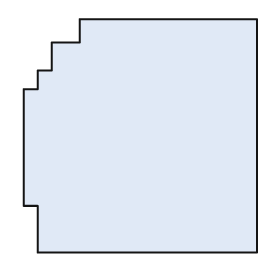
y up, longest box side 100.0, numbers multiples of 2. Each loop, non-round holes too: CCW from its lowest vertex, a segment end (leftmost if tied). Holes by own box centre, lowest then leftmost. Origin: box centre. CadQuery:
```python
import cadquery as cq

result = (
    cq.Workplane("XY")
    .moveTo(-44.0, -50.0)
    .lineTo(50.0, -50.0)
    .lineTo(50.0, 50.0)
    .lineTo(-26.0, 50.0)
    .lineTo(-26.0, 40.0)
    .lineTo(-38.0, 40.0)
    .lineTo(-38.0, 28.0)
    .lineTo(-44.0, 28.0)
    .lineTo(-44.0, 20.0)
    .lineTo(-50.0, 20.0)
    .lineTo(-50.0, -30.0)
    .lineTo(-44.0, -30.0)
    .close()
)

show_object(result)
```